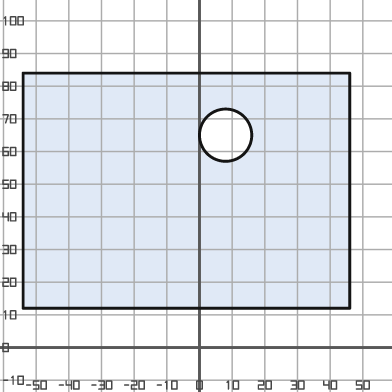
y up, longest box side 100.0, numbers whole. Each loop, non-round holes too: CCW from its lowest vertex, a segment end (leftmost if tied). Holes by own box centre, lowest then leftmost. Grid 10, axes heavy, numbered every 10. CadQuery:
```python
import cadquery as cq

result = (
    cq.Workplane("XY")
    .moveTo(-54.0, 12.0)
    .lineTo(46.0, 12.0)
    .lineTo(46.0, 84.0)
    .lineTo(-54.0, 84.0)
    .close()
    .moveTo(8.0, 65.0)
    .circle(8.0)
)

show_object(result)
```